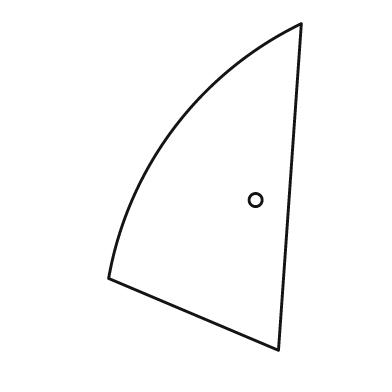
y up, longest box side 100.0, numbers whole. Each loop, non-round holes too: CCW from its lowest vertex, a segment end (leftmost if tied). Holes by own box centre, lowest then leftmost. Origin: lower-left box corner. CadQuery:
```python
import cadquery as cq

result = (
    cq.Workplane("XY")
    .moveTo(52.0, 0.0)
    .lineTo(59.0, 100.0)
    .threePointArc((20.0, 68.0), (0.0, 22.0))
    .close()
    .moveTo(45.0, 46.0)
    .circle(2.0)
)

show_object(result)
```